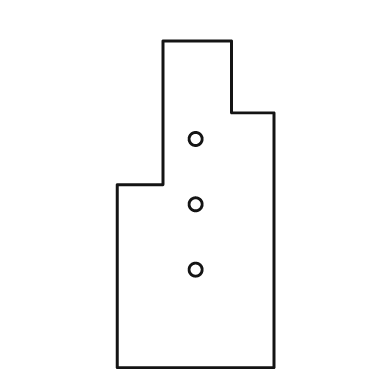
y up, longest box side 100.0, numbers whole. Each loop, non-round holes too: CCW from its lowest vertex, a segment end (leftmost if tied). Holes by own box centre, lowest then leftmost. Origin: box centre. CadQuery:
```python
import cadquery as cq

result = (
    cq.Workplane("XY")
    .moveTo(-24.0, -50.0)
    .lineTo(24.0, -50.0)
    .lineTo(24.0, 28.0)
    .lineTo(11.0, 28.0)
    .lineTo(11.0, 50.0)
    .lineTo(-10.0, 50.0)
    .lineTo(-10.0, 6.0)
    .lineTo(-24.0, 6.0)
    .close()
    .moveTo(0.0, -20.0)
    .circle(2.0)
    .moveTo(0.0, 0.0)
    .circle(2.0)
    .moveTo(0.0, 20.0)
    .circle(2.0)
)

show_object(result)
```